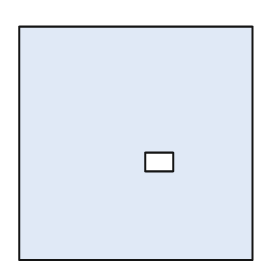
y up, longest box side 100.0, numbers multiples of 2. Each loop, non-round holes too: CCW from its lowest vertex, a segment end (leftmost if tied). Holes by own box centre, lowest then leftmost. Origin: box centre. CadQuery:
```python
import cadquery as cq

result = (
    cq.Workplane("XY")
    .moveTo(-50.0, -50.0)
    .lineTo(50.0, -50.0)
    .lineTo(50.0, 50.0)
    .lineTo(-50.0, 50.0)
    .close()
    .moveTo(4.0, -12.0)
    .lineTo(16.0, -12.0)
    .lineTo(16.0, -4.0)
    .lineTo(4.0, -4.0)
    .close()
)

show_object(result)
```